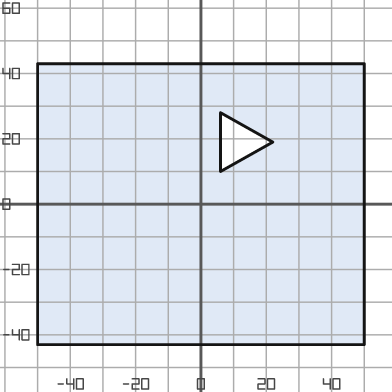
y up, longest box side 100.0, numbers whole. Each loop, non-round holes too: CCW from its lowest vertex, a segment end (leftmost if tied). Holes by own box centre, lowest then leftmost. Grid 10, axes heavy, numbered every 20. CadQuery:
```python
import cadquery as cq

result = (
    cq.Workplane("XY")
    .moveTo(-50.0, -43.0)
    .lineTo(50.0, -43.0)
    .lineTo(50.0, 43.0)
    .lineTo(-50.0, 43.0)
    .close()
    .moveTo(6.0, 10.0)
    .lineTo(22.0, 19.0)
    .lineTo(6.0, 28.0)
    .close()
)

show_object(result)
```